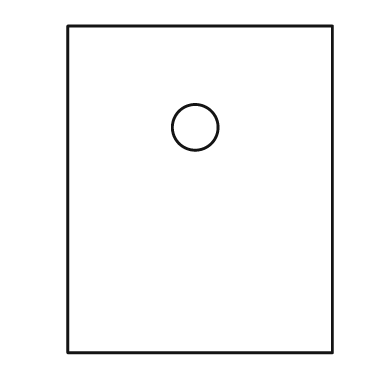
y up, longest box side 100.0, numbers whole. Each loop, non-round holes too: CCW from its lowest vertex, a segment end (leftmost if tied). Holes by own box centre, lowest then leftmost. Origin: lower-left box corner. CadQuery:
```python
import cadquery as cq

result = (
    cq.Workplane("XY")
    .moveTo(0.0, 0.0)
    .lineTo(81.0, 0.0)
    .lineTo(81.0, 100.0)
    .lineTo(0.0, 100.0)
    .close()
    .moveTo(39.0, 69.0)
    .circle(7.0)
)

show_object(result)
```